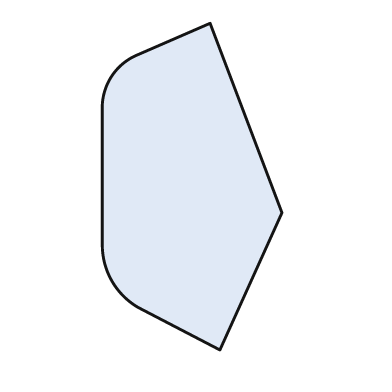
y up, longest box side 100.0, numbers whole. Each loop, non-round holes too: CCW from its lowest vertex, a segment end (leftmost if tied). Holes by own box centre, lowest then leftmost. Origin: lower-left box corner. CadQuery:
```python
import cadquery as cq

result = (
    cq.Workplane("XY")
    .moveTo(36.0, 0.0)
    .lineTo(55.0, 42.0)
    .lineTo(33.0, 100.0)
    .lineTo(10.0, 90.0)
    .threePointArc((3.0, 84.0), (0.0, 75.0))
    .lineTo(0.0, 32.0)
    .threePointArc((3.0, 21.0), (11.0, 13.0))
    .close()
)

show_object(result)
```